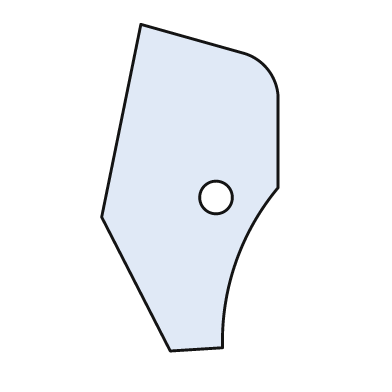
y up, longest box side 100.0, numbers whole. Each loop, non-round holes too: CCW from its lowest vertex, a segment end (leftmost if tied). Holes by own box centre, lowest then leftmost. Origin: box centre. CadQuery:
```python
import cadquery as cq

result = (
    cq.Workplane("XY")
    .moveTo(-6.0, -50.0)
    .lineTo(10.0, -49.0)
    .threePointArc((14.0, -23.0), (27.0, 0.0))
    .lineTo(27.0, 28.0)
    .threePointArc((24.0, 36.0), (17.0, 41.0))
    .lineTo(-15.0, 50.0)
    .lineTo(-27.0, -9.0)
    .close()
    .moveTo(8.0, -3.0)
    .circle(5.0)
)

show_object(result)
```